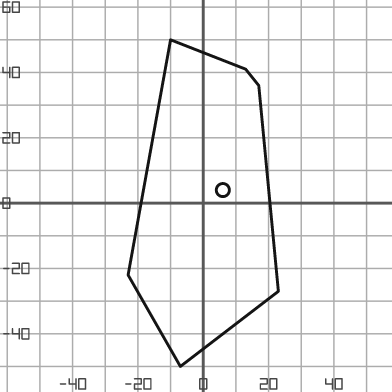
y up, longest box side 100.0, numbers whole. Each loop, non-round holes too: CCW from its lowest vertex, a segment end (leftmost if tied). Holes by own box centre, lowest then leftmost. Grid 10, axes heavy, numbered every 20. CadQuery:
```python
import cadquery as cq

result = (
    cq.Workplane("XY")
    .moveTo(-7.0, -50.0)
    .lineTo(23.0, -27.0)
    .lineTo(17.0, 36.0)
    .lineTo(13.0, 41.0)
    .lineTo(-10.0, 50.0)
    .lineTo(-23.0, -22.0)
    .close()
    .moveTo(6.0, 4.0)
    .circle(2.0)
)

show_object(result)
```